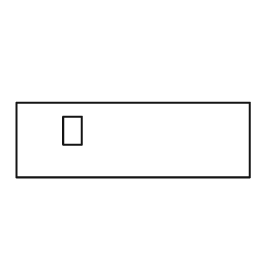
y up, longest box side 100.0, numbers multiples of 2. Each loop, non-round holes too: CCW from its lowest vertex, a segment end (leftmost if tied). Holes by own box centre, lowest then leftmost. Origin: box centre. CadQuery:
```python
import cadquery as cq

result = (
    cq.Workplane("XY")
    .moveTo(-50.0, -16.0)
    .lineTo(50.0, -16.0)
    .lineTo(50.0, 16.0)
    .lineTo(-50.0, 16.0)
    .close()
    .moveTo(-30.0, -2.0)
    .lineTo(-22.0, -2.0)
    .lineTo(-22.0, 10.0)
    .lineTo(-30.0, 10.0)
    .close()
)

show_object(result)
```